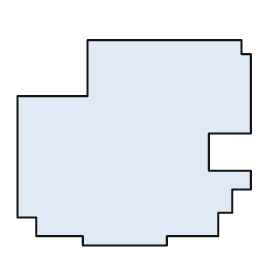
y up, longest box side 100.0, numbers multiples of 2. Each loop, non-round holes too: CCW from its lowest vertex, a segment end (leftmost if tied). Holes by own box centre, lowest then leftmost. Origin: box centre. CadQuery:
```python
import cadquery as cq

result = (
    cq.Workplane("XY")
    .moveTo(-22.0, -44.0)
    .lineTo(14.0, -44.0)
    .lineTo(14.0, -40.0)
    .lineTo(36.0, -40.0)
    .lineTo(36.0, -30.0)
    .lineTo(42.0, -30.0)
    .lineTo(42.0, -20.0)
    .lineTo(50.0, -20.0)
    .lineTo(50.0, -12.0)
    .lineTo(32.0, -12.0)
    .lineTo(32.0, 4.0)
    .lineTo(50.0, 4.0)
    .lineTo(50.0, 38.0)
    .lineTo(46.0, 38.0)
    .lineTo(46.0, 44.0)
    .lineTo(-20.0, 44.0)
    .lineTo(-20.0, 20.0)
    .lineTo(-50.0, 20.0)
    .lineTo(-50.0, -32.0)
    .lineTo(-42.0, -32.0)
    .lineTo(-42.0, -40.0)
    .lineTo(-22.0, -40.0)
    .close()
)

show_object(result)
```